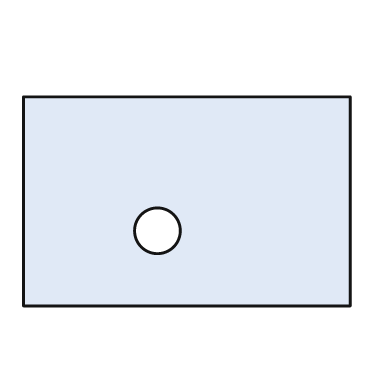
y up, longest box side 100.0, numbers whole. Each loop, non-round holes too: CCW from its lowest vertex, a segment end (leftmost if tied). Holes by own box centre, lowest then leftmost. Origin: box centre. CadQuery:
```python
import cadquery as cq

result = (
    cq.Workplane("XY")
    .moveTo(-50.0, -32.0)
    .lineTo(50.0, -32.0)
    .lineTo(50.0, 32.0)
    .lineTo(-50.0, 32.0)
    .close()
    .moveTo(-9.0, -9.0)
    .circle(7.0)
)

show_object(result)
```